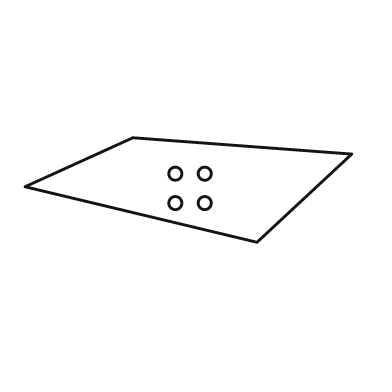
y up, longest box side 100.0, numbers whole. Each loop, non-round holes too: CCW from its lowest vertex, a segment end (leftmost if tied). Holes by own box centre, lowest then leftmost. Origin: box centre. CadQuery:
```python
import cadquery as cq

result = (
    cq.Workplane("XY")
    .moveTo(21.0, -16.0)
    .lineTo(50.0, 11.0)
    .lineTo(-17.0, 16.0)
    .lineTo(-50.0, 1.0)
    .close()
    .moveTo(-4.0, -4.0)
    .circle(2.0)
    .moveTo(5.0, -4.0)
    .circle(2.0)
    .moveTo(-4.0, 5.0)
    .circle(2.0)
    .moveTo(5.0, 5.0)
    .circle(2.0)
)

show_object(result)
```